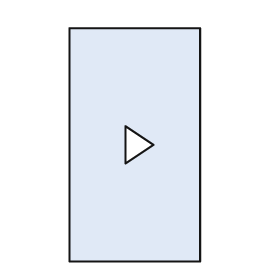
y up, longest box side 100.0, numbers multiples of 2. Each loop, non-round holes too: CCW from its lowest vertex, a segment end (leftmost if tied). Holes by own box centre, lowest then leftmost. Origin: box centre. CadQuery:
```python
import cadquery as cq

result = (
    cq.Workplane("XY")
    .moveTo(-28.0, -50.0)
    .lineTo(28.0, -50.0)
    .lineTo(28.0, 50.0)
    .lineTo(-28.0, 50.0)
    .close()
    .moveTo(-4.0, -8.0)
    .lineTo(8.0, 0.0)
    .lineTo(-4.0, 8.0)
    .close()
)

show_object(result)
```